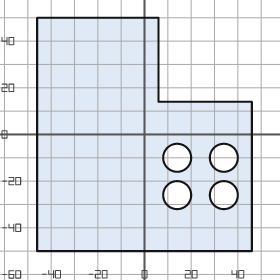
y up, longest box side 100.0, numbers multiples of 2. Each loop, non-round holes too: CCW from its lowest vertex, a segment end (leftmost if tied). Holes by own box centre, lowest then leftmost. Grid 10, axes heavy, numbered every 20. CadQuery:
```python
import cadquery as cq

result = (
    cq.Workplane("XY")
    .moveTo(-46.0, -50.0)
    .lineTo(46.0, -50.0)
    .lineTo(46.0, 14.0)
    .lineTo(6.0, 14.0)
    .lineTo(6.0, 50.0)
    .lineTo(-46.0, 50.0)
    .close()
    .moveTo(14.0, -26.0)
    .circle(6.0)
    .moveTo(34.0, -26.0)
    .circle(6.0)
    .moveTo(14.0, -10.0)
    .circle(6.0)
    .moveTo(34.0, -10.0)
    .circle(6.0)
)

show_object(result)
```